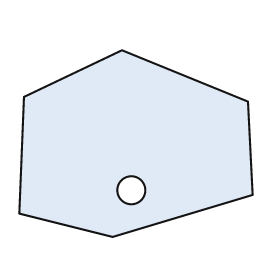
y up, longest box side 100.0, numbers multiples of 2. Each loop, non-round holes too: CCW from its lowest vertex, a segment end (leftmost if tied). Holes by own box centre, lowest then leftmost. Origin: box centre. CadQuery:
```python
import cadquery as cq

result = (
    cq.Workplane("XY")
    .moveTo(-10.0, -40.0)
    .lineTo(50.0, -22.0)
    .lineTo(48.0, 18.0)
    .lineTo(-6.0, 40.0)
    .lineTo(-48.0, 20.0)
    .lineTo(-50.0, -30.0)
    .close()
    .moveTo(-2.0, -20.0)
    .circle(6.0)
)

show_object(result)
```